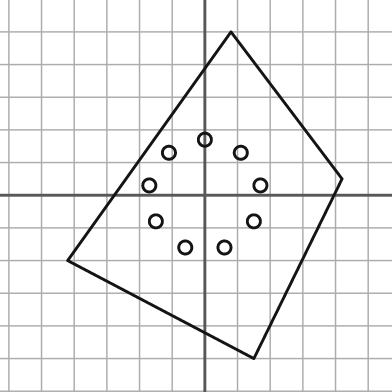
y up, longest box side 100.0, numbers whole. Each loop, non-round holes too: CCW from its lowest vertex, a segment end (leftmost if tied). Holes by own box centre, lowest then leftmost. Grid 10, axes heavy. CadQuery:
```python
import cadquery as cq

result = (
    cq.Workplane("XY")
    .moveTo(15.0, -50.0)
    .lineTo(42.0, 5.0)
    .lineTo(8.0, 50.0)
    .lineTo(-42.0, -20.0)
    .close()
    .moveTo(-6.0, -16.0)
    .circle(2.0)
    .moveTo(6.0, -16.0)
    .circle(2.0)
    .moveTo(-15.0, -8.0)
    .circle(2.0)
    .moveTo(15.0, -8.0)
    .circle(2.0)
    .moveTo(-17.0, 3.0)
    .circle(2.0)
    .moveTo(17.0, 3.0)
    .circle(2.0)
    .moveTo(-11.0, 13.0)
    .circle(2.0)
    .moveTo(11.0, 13.0)
    .circle(2.0)
    .moveTo(0.0, 17.0)
    .circle(2.0)
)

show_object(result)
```